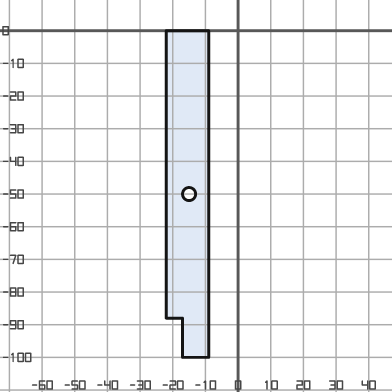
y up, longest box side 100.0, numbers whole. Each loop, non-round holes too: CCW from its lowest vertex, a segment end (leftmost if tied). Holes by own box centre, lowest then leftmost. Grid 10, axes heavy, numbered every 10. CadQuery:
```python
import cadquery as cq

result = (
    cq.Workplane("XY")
    .moveTo(-17.0, -100.0)
    .lineTo(-9.0, -100.0)
    .lineTo(-9.0, 0.0)
    .lineTo(-22.0, 0.0)
    .lineTo(-22.0, -88.0)
    .lineTo(-17.0, -88.0)
    .close()
    .moveTo(-15.0, -50.0)
    .circle(2.0)
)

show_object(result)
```